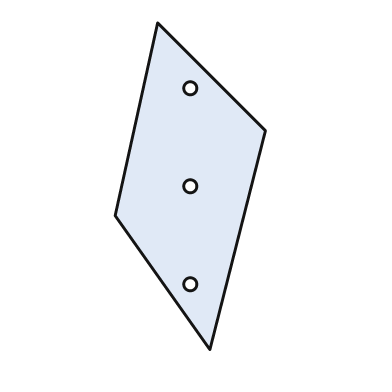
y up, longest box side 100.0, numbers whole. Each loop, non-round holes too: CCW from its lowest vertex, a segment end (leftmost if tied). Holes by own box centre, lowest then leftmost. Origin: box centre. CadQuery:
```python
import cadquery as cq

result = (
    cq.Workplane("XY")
    .moveTo(6.0, -50.0)
    .lineTo(23.0, 17.0)
    .lineTo(-10.0, 50.0)
    .lineTo(-23.0, -9.0)
    .close()
    .moveTo(0.0, -30.0)
    .circle(2.0)
    .moveTo(0.0, 0.0)
    .circle(2.0)
    .moveTo(0.0, 30.0)
    .circle(2.0)
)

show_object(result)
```